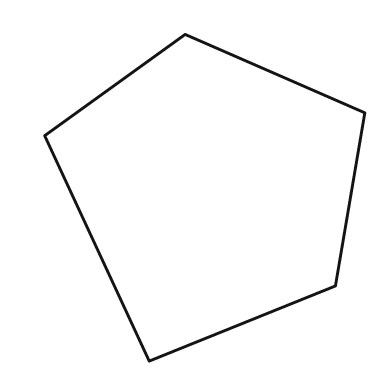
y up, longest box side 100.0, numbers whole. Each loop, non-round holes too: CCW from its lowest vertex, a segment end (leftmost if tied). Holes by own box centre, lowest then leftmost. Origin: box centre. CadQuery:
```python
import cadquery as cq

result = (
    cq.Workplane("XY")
    .moveTo(-17.0, -50.0)
    .lineTo(40.0, -27.0)
    .lineTo(49.0, 26.0)
    .lineTo(-6.0, 50.0)
    .lineTo(-49.0, 19.0)
    .close()
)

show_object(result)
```